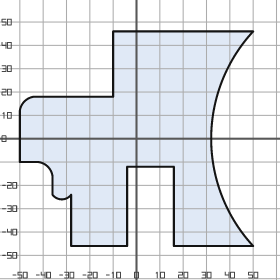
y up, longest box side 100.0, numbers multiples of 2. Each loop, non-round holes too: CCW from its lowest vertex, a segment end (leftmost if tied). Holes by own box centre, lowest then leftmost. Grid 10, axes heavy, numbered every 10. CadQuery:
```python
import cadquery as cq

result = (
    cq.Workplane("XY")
    .moveTo(-28.0, -46.0)
    .lineTo(-4.0, -46.0)
    .lineTo(-4.0, -12.0)
    .lineTo(16.0, -12.0)
    .lineTo(16.0, -46.0)
    .lineTo(50.0, -46.0)
    .threePointArc((32.0, 0.0), (50.0, 46.0))
    .lineTo(-10.0, 46.0)
    .lineTo(-10.0, 18.0)
    .lineTo(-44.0, 18.0)
    .threePointArc((-48.0, 16.0), (-50.0, 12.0))
    .lineTo(-50.0, -10.0)
    .lineTo(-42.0, -10.0)
    .threePointArc((-38.0, -12.0), (-36.0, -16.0))
    .lineTo(-36.0, -24.0)
    .threePointArc((-32.0, -26.0), (-28.0, -24.0))
    .close()
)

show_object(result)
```